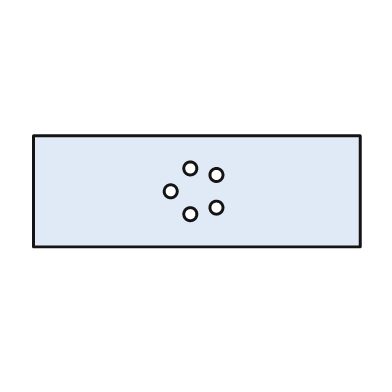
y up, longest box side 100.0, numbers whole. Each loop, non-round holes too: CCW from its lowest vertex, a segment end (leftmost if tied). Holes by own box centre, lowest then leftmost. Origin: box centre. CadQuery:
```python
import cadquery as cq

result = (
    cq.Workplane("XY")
    .moveTo(-50.0, -17.0)
    .lineTo(50.0, -17.0)
    .lineTo(50.0, 17.0)
    .lineTo(-50.0, 17.0)
    .close()
    .moveTo(-2.0, -7.0)
    .circle(2.0)
    .moveTo(6.0, -5.0)
    .circle(2.0)
    .moveTo(-8.0, 0.0)
    .circle(2.0)
    .moveTo(6.0, 5.0)
    .circle(2.0)
    .moveTo(-2.0, 7.0)
    .circle(2.0)
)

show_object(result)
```